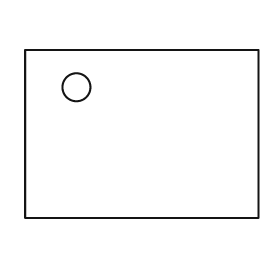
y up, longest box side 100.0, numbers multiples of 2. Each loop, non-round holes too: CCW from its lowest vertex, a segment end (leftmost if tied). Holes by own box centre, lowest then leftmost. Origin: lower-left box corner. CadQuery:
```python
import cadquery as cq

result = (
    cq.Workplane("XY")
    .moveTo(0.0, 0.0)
    .lineTo(100.0, 0.0)
    .lineTo(100.0, 72.0)
    .lineTo(0.0, 72.0)
    .close()
    .moveTo(22.0, 56.0)
    .circle(6.0)
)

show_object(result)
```